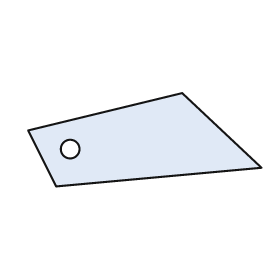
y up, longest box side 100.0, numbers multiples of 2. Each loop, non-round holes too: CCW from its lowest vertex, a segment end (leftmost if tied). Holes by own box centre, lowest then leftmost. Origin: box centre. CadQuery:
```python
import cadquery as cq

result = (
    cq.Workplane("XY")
    .moveTo(-38.0, -20.0)
    .lineTo(50.0, -12.0)
    .lineTo(16.0, 20.0)
    .lineTo(-50.0, 4.0)
    .close()
    .moveTo(-32.0, -4.0)
    .circle(4.0)
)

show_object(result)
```